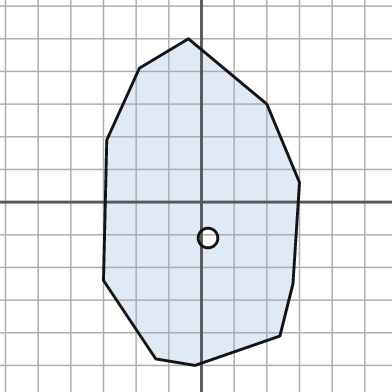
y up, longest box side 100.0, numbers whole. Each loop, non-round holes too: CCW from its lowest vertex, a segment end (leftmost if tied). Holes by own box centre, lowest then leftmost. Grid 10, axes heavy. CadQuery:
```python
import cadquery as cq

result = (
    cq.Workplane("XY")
    .moveTo(-2.0, -50.0)
    .lineTo(24.0, -41.0)
    .lineTo(28.0, -25.0)
    .lineTo(30.0, 6.0)
    .lineTo(20.0, 30.0)
    .lineTo(-4.0, 50.0)
    .lineTo(-19.0, 41.0)
    .lineTo(-29.0, 19.0)
    .lineTo(-30.0, -24.0)
    .lineTo(-14.0, -48.0)
    .close()
    .moveTo(2.0, -11.0)
    .circle(3.0)
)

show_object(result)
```